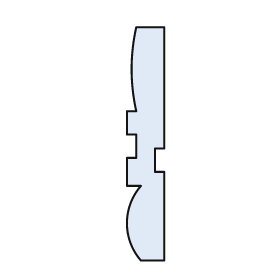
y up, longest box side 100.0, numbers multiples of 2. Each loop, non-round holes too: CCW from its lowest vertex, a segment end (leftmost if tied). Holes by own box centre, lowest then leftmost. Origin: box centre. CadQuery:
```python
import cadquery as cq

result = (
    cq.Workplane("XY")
    .moveTo(-2.0, -50.0)
    .lineTo(8.0, -50.0)
    .lineTo(8.0, -12.0)
    .lineTo(4.0, -12.0)
    .lineTo(4.0, -2.0)
    .lineTo(8.0, -2.0)
    .lineTo(8.0, 50.0)
    .lineTo(-4.0, 50.0)
    .threePointArc((-6.0, 32.0), (-4.0, 14.0))
    .lineTo(-8.0, 14.0)
    .lineTo(-8.0, 4.0)
    .lineTo(-4.0, 4.0)
    .lineTo(-4.0, -6.0)
    .lineTo(-8.0, -6.0)
    .lineTo(-8.0, -18.0)
    .lineTo(-2.0, -18.0)
    .threePointArc((-8.0, -34.0), (-2.0, -50.0))
    .close()
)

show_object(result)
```